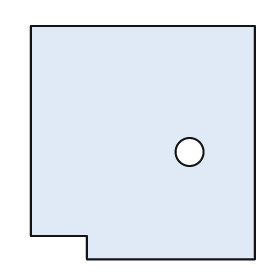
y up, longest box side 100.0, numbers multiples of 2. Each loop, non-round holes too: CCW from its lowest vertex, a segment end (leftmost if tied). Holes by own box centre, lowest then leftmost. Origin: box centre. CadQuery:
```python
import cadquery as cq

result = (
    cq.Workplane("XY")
    .moveTo(-24.0, -50.0)
    .lineTo(48.0, -50.0)
    .lineTo(48.0, 50.0)
    .lineTo(-48.0, 50.0)
    .lineTo(-48.0, -40.0)
    .lineTo(-24.0, -40.0)
    .close()
    .moveTo(20.0, -4.0)
    .circle(6.0)
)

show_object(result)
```